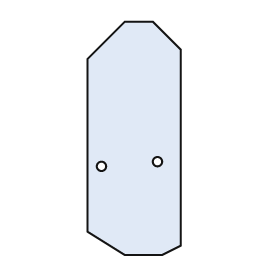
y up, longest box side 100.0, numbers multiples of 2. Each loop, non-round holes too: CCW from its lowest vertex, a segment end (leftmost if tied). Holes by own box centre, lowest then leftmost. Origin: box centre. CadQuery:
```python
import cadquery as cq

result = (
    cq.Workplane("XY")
    .moveTo(-4.0, -50.0)
    .lineTo(12.0, -50.0)
    .lineTo(20.0, -46.0)
    .lineTo(20.0, 38.0)
    .lineTo(8.0, 50.0)
    .lineTo(-4.0, 50.0)
    .lineTo(-20.0, 34.0)
    .lineTo(-20.0, -40.0)
    .close()
    .moveTo(-14.0, -12.0)
    .circle(2.0)
    .moveTo(10.0, -10.0)
    .circle(2.0)
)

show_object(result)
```